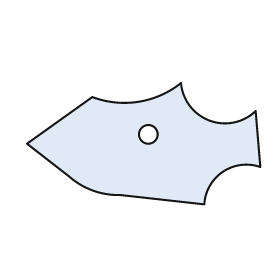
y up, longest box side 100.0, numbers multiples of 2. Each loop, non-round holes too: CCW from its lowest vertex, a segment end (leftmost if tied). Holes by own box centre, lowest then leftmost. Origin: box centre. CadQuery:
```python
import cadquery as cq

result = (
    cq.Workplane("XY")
    .moveTo(26.0, -26.0)
    .threePointArc((34.0, -12.0), (50.0, -10.0))
    .lineTo(48.0, 14.0)
    .threePointArc((28.0, 10.0), (16.0, 26.0))
    .threePointArc((-2.0, 18.0), (-22.0, 20.0))
    .lineTo(-50.0, 0.0)
    .lineTo(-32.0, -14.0)
    .threePointArc((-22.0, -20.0), (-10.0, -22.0))
    .close()
    .moveTo(2.0, 4.0)
    .circle(4.0)
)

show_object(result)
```